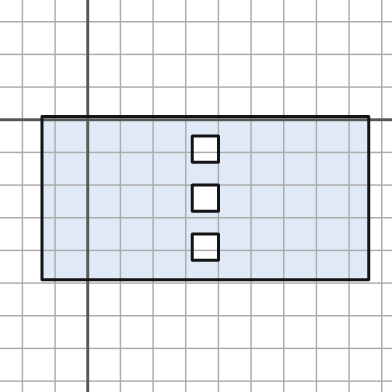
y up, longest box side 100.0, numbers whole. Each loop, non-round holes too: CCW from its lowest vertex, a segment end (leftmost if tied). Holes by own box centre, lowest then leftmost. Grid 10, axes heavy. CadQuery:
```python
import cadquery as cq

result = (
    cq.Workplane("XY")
    .moveTo(-14.0, -49.0)
    .lineTo(86.0, -49.0)
    .lineTo(86.0, 1.0)
    .lineTo(-14.0, 1.0)
    .close()
    .moveTo(32.0, -43.0)
    .lineTo(40.0, -43.0)
    .lineTo(40.0, -35.0)
    .lineTo(32.0, -35.0)
    .close()
    .moveTo(32.0, -28.0)
    .lineTo(40.0, -28.0)
    .lineTo(40.0, -20.0)
    .lineTo(32.0, -20.0)
    .close()
    .moveTo(32.0, -13.0)
    .lineTo(40.0, -13.0)
    .lineTo(40.0, -5.0)
    .lineTo(32.0, -5.0)
    .close()
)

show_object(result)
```